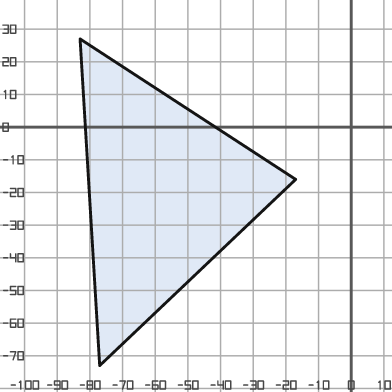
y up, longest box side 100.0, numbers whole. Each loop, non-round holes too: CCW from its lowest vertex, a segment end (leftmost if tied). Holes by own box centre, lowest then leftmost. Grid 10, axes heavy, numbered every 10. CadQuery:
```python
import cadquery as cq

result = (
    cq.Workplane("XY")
    .moveTo(-77.0, -73.0)
    .lineTo(-17.0, -16.0)
    .lineTo(-83.0, 27.0)
    .close()
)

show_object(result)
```